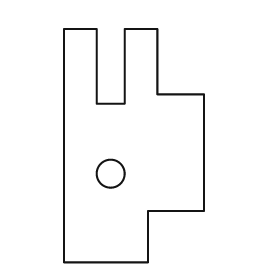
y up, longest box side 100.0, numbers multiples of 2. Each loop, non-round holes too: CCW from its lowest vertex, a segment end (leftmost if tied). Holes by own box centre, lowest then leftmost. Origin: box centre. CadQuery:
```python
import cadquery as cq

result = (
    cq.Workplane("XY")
    .moveTo(-30.0, -50.0)
    .lineTo(6.0, -50.0)
    .lineTo(6.0, -28.0)
    .lineTo(30.0, -28.0)
    .lineTo(30.0, 22.0)
    .lineTo(10.0, 22.0)
    .lineTo(10.0, 50.0)
    .lineTo(-4.0, 50.0)
    .lineTo(-4.0, 18.0)
    .lineTo(-16.0, 18.0)
    .lineTo(-16.0, 50.0)
    .lineTo(-30.0, 50.0)
    .close()
    .moveTo(-10.0, -12.0)
    .circle(6.0)
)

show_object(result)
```